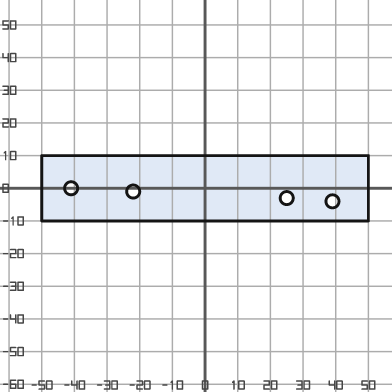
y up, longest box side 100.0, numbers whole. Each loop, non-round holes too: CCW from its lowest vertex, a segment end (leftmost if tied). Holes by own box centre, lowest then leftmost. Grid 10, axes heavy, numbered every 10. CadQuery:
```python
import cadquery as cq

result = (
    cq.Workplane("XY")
    .moveTo(-50.0, -10.0)
    .lineTo(50.0, -10.0)
    .lineTo(50.0, 10.0)
    .lineTo(-50.0, 10.0)
    .close()
    .moveTo(39.0, -4.0)
    .circle(2.0)
    .moveTo(25.0, -3.0)
    .circle(2.0)
    .moveTo(-22.0, -1.0)
    .circle(2.0)
    .moveTo(-41.0, 0.0)
    .circle(2.0)
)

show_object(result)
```